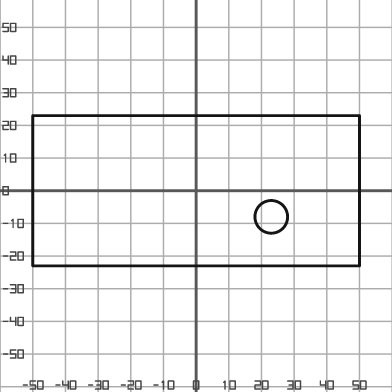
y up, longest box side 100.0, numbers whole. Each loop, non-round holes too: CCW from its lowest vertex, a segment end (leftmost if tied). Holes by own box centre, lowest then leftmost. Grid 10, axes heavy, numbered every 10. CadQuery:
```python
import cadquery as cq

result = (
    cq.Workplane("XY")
    .moveTo(-50.0, -23.0)
    .lineTo(50.0, -23.0)
    .lineTo(50.0, 23.0)
    .lineTo(-50.0, 23.0)
    .close()
    .moveTo(23.0, -8.0)
    .circle(5.0)
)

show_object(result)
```